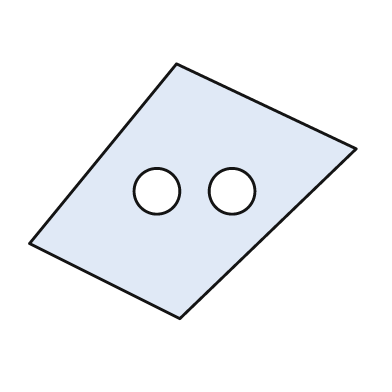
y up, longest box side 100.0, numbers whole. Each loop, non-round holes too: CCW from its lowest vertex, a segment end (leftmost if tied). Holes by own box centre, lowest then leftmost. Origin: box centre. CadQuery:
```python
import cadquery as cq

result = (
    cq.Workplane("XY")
    .moveTo(-4.0, -39.0)
    .lineTo(50.0, 13.0)
    .lineTo(-5.0, 39.0)
    .lineTo(-50.0, -16.0)
    .close()
    .moveTo(-11.0, 0.0)
    .circle(7.0)
    .moveTo(12.0, 0.0)
    .circle(7.0)
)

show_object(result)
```